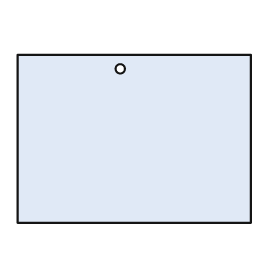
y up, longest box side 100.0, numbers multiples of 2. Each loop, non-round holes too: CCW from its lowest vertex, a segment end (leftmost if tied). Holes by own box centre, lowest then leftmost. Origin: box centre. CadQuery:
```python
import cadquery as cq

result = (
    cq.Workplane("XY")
    .moveTo(-50.0, -36.0)
    .lineTo(50.0, -36.0)
    .lineTo(50.0, 36.0)
    .lineTo(-50.0, 36.0)
    .close()
    .moveTo(-6.0, 30.0)
    .circle(2.0)
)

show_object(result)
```